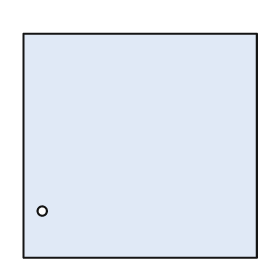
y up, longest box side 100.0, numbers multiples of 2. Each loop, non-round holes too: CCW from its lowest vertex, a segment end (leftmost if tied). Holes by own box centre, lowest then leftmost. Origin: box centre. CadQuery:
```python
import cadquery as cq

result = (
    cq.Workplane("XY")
    .moveTo(-50.0, -48.0)
    .lineTo(50.0, -48.0)
    .lineTo(50.0, 48.0)
    .lineTo(-50.0, 48.0)
    .close()
    .moveTo(-42.0, -28.0)
    .circle(2.0)
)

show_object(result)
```